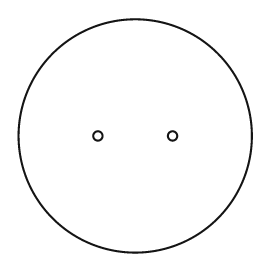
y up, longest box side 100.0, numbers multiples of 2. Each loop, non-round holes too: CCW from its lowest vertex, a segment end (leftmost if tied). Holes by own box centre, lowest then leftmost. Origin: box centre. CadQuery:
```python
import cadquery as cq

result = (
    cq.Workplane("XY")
    .moveTo(0.0, 0.0)
    .circle(50.0)
    .moveTo(-16.0, 0.0)
    .circle(2.0)
    .moveTo(16.0, 0.0)
    .circle(2.0)
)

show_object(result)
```